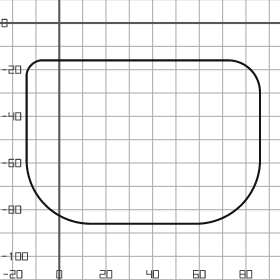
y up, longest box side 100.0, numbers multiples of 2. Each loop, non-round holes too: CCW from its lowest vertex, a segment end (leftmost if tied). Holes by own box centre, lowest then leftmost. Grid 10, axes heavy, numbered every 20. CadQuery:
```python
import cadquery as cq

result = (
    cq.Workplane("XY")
    .moveTo(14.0, -86.0)
    .lineTo(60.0, -86.0)
    .threePointArc((78.0, -78.0), (86.0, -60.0))
    .lineTo(86.0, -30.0)
    .threePointArc((82.0, -20.0), (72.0, -16.0))
    .lineTo(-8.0, -16.0)
    .threePointArc((-12.0, -18.0), (-14.0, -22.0))
    .lineTo(-14.0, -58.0)
    .threePointArc((-6.0, -78.0), (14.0, -86.0))
    .close()
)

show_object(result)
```